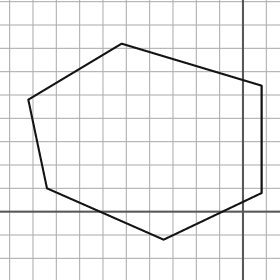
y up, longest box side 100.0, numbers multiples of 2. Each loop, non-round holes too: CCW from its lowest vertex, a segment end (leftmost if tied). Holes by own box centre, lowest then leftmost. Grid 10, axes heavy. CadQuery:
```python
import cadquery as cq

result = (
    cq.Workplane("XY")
    .moveTo(-34.0, -12.0)
    .lineTo(8.0, 8.0)
    .lineTo(8.0, 54.0)
    .lineTo(-52.0, 72.0)
    .lineTo(-92.0, 48.0)
    .lineTo(-84.0, 10.0)
    .close()
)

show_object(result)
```